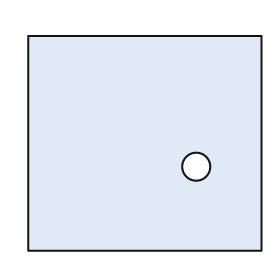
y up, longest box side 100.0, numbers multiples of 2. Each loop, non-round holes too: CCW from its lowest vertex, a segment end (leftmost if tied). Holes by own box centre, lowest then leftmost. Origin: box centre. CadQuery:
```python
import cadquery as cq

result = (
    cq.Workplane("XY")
    .moveTo(-50.0, -46.0)
    .lineTo(50.0, -46.0)
    .lineTo(50.0, 46.0)
    .lineTo(-50.0, 46.0)
    .close()
    .moveTo(22.0, -10.0)
    .circle(6.0)
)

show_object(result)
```